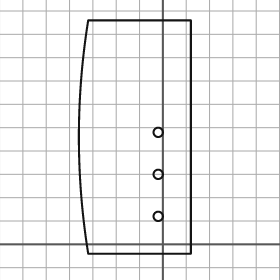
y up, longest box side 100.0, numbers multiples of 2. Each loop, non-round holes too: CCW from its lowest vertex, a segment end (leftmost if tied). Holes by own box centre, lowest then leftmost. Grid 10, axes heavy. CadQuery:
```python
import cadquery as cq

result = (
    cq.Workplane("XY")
    .moveTo(-32.0, -4.0)
    .lineTo(12.0, -4.0)
    .lineTo(12.0, 96.0)
    .lineTo(-32.0, 96.0)
    .threePointArc((-36.0, 46.0), (-32.0, -4.0))
    .close()
    .moveTo(-2.0, 12.0)
    .circle(2.0)
    .moveTo(-2.0, 30.0)
    .circle(2.0)
    .moveTo(-2.0, 48.0)
    .circle(2.0)
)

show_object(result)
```